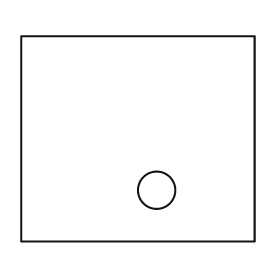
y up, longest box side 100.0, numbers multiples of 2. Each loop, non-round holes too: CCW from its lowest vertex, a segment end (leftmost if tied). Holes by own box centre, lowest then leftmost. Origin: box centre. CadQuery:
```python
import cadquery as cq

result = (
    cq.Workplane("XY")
    .moveTo(-50.0, -44.0)
    .lineTo(50.0, -44.0)
    .lineTo(50.0, 44.0)
    .lineTo(-50.0, 44.0)
    .close()
    .moveTo(8.0, -22.0)
    .circle(8.0)
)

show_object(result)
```